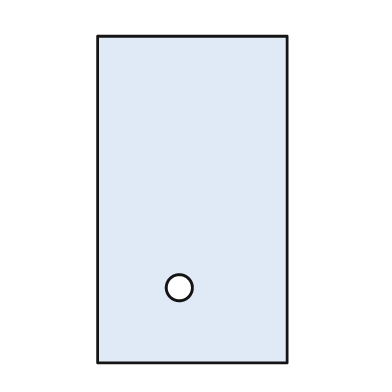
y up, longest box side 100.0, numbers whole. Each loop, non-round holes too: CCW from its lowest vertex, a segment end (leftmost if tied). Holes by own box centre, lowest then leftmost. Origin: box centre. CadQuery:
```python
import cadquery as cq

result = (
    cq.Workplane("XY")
    .moveTo(-29.0, -50.0)
    .lineTo(29.0, -50.0)
    .lineTo(29.0, 50.0)
    .lineTo(-29.0, 50.0)
    .close()
    .moveTo(-4.0, -27.0)
    .circle(4.0)
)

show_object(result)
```